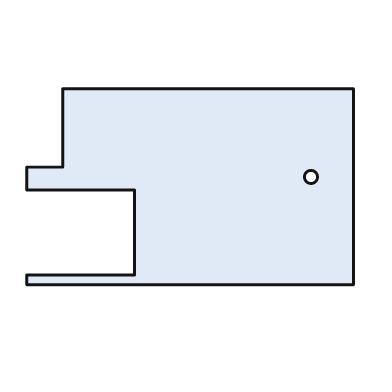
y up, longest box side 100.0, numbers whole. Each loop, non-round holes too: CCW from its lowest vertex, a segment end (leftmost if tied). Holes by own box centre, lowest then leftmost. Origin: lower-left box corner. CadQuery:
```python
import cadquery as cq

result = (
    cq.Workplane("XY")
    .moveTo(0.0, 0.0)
    .lineTo(100.0, 0.0)
    .lineTo(100.0, 60.0)
    .lineTo(11.0, 60.0)
    .lineTo(11.0, 36.0)
    .lineTo(0.0, 36.0)
    .lineTo(0.0, 29.0)
    .lineTo(33.0, 29.0)
    .lineTo(33.0, 3.0)
    .lineTo(0.0, 3.0)
    .close()
    .moveTo(87.0, 33.0)
    .circle(2.0)
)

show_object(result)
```